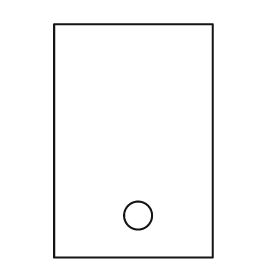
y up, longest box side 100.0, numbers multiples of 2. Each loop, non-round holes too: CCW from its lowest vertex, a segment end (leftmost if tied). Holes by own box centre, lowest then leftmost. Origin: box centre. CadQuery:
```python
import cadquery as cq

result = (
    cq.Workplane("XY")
    .moveTo(-34.0, -50.0)
    .lineTo(34.0, -50.0)
    .lineTo(34.0, 50.0)
    .lineTo(-34.0, 50.0)
    .close()
    .moveTo(2.0, -32.0)
    .circle(6.0)
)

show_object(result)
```